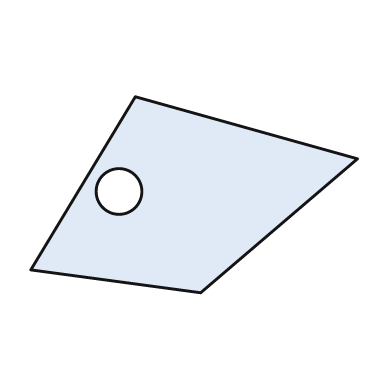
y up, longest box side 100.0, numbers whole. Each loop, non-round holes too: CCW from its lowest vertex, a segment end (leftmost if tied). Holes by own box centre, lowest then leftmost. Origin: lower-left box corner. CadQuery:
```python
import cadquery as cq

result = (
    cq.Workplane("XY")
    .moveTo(52.0, 0.0)
    .lineTo(100.0, 41.0)
    .lineTo(32.0, 60.0)
    .lineTo(0.0, 7.0)
    .close()
    .moveTo(27.0, 31.0)
    .circle(7.0)
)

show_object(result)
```